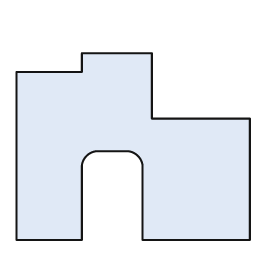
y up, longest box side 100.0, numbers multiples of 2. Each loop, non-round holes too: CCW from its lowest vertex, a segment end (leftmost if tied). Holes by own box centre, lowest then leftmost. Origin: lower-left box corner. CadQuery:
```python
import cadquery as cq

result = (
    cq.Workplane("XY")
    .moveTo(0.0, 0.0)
    .lineTo(28.0, 0.0)
    .lineTo(28.0, 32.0)
    .threePointArc((30.0, 36.0), (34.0, 38.0))
    .lineTo(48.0, 38.0)
    .threePointArc((52.0, 36.0), (54.0, 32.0))
    .lineTo(54.0, 0.0)
    .lineTo(100.0, 0.0)
    .lineTo(100.0, 52.0)
    .lineTo(58.0, 52.0)
    .lineTo(58.0, 80.0)
    .lineTo(28.0, 80.0)
    .lineTo(28.0, 72.0)
    .lineTo(0.0, 72.0)
    .close()
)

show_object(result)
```